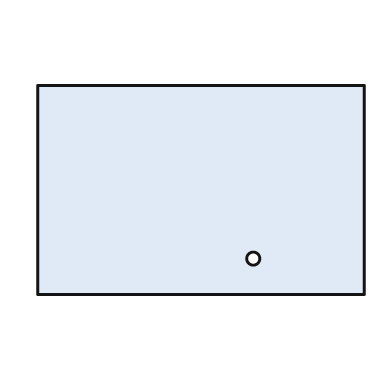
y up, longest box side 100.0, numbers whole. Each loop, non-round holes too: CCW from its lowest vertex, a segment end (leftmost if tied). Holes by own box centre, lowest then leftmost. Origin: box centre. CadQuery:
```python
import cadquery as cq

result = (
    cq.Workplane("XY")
    .moveTo(-50.0, -32.0)
    .lineTo(50.0, -32.0)
    .lineTo(50.0, 32.0)
    .lineTo(-50.0, 32.0)
    .close()
    .moveTo(16.0, -21.0)
    .circle(2.0)
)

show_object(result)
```